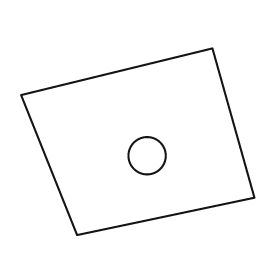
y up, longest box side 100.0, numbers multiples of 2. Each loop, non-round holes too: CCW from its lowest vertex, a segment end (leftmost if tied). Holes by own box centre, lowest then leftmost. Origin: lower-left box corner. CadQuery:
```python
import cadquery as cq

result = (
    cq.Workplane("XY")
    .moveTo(24.0, 0.0)
    .lineTo(100.0, 16.0)
    .lineTo(82.0, 80.0)
    .lineTo(0.0, 60.0)
    .close()
    .moveTo(54.0, 34.0)
    .circle(8.0)
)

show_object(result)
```